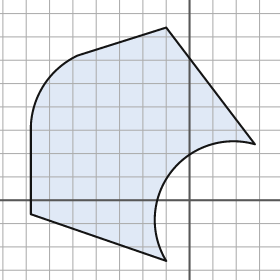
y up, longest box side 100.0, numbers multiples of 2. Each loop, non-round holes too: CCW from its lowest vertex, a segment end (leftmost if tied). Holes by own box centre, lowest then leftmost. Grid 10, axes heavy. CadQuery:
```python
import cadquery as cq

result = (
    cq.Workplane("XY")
    .moveTo(-10.0, -26.0)
    .threePointArc((-8.0, 12.0), (28.0, 24.0))
    .lineTo(-10.0, 74.0)
    .lineTo(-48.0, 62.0)
    .threePointArc((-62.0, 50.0), (-68.0, 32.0))
    .lineTo(-68.0, -6.0)
    .close()
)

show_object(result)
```